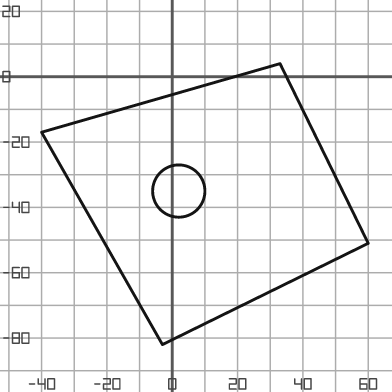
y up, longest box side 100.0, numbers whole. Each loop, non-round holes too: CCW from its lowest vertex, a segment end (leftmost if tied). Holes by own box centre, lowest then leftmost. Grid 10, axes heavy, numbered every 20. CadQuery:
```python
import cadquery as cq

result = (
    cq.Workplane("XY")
    .moveTo(-3.0, -82.0)
    .lineTo(60.0, -51.0)
    .lineTo(33.0, 4.0)
    .lineTo(-40.0, -17.0)
    .close()
    .moveTo(2.0, -35.0)
    .circle(8.0)
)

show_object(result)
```